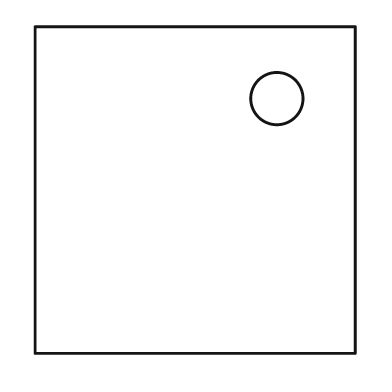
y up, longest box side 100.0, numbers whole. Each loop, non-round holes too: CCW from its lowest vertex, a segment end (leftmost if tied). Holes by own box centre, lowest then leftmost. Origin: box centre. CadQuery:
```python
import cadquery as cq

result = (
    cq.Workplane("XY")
    .moveTo(-49.0, -50.0)
    .lineTo(49.0, -50.0)
    .lineTo(49.0, 50.0)
    .lineTo(-49.0, 50.0)
    .close()
    .moveTo(25.0, 28.0)
    .circle(8.0)
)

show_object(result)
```